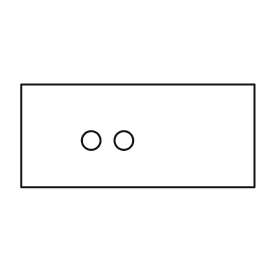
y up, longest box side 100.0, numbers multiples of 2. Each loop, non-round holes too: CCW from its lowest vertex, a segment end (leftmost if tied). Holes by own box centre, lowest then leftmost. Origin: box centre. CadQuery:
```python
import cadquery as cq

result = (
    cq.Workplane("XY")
    .moveTo(-50.0, -22.0)
    .lineTo(50.0, -22.0)
    .lineTo(50.0, 22.0)
    .lineTo(-50.0, 22.0)
    .close()
    .moveTo(-20.0, -2.0)
    .circle(4.0)
    .moveTo(-6.0, -2.0)
    .circle(4.0)
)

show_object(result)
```